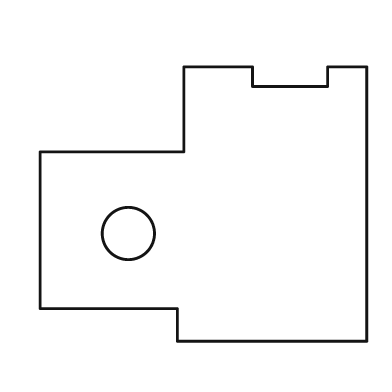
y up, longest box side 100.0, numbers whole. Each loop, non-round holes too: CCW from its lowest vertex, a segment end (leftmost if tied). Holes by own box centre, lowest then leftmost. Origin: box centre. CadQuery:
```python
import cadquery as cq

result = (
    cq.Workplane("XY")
    .moveTo(-8.0, -42.0)
    .lineTo(50.0, -42.0)
    .lineTo(50.0, 42.0)
    .lineTo(38.0, 42.0)
    .lineTo(38.0, 36.0)
    .lineTo(15.0, 36.0)
    .lineTo(15.0, 42.0)
    .lineTo(-6.0, 42.0)
    .lineTo(-6.0, 16.0)
    .lineTo(-50.0, 16.0)
    .lineTo(-50.0, -32.0)
    .lineTo(-8.0, -32.0)
    .close()
    .moveTo(-23.0, -9.0)
    .circle(8.0)
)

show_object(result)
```